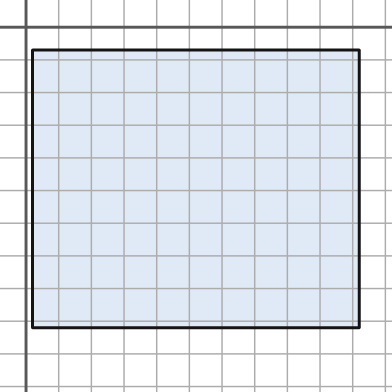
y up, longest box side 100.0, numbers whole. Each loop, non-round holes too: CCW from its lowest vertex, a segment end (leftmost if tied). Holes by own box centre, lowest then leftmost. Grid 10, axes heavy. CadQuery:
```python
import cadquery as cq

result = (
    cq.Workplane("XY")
    .moveTo(2.0, -92.0)
    .lineTo(102.0, -92.0)
    .lineTo(102.0, -7.0)
    .lineTo(2.0, -7.0)
    .close()
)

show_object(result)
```